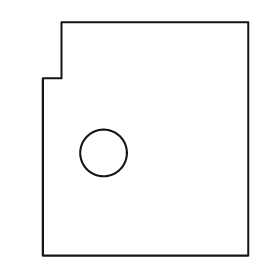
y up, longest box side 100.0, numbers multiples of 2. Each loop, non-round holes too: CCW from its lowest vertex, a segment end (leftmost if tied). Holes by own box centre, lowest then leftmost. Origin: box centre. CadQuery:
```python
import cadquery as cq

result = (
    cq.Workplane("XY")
    .moveTo(-44.0, -50.0)
    .lineTo(44.0, -50.0)
    .lineTo(44.0, 50.0)
    .lineTo(-36.0, 50.0)
    .lineTo(-36.0, 26.0)
    .lineTo(-44.0, 26.0)
    .close()
    .moveTo(-18.0, -6.0)
    .circle(10.0)
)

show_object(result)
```